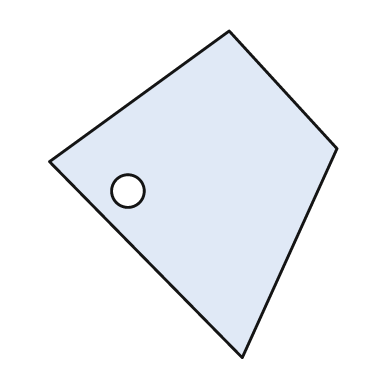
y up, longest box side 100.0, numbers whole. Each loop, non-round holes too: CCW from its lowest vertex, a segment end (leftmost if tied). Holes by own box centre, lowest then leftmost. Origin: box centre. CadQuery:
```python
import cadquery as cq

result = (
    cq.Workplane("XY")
    .moveTo(15.0, -50.0)
    .lineTo(44.0, 14.0)
    .lineTo(11.0, 50.0)
    .lineTo(-44.0, 10.0)
    .close()
    .moveTo(-20.0, 1.0)
    .circle(5.0)
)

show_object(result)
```